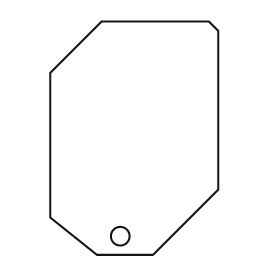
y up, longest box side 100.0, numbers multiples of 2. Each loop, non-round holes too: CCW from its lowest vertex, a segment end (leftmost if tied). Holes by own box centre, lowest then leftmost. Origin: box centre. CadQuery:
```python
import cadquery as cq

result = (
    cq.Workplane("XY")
    .moveTo(-16.0, -50.0)
    .lineTo(8.0, -50.0)
    .lineTo(36.0, -22.0)
    .lineTo(36.0, 46.0)
    .lineTo(32.0, 50.0)
    .lineTo(-14.0, 50.0)
    .lineTo(-36.0, 28.0)
    .lineTo(-36.0, -34.0)
    .close()
    .moveTo(-6.0, -42.0)
    .circle(4.0)
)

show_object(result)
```